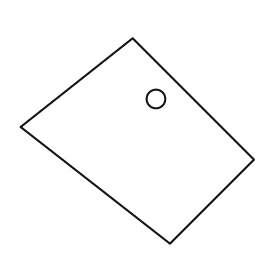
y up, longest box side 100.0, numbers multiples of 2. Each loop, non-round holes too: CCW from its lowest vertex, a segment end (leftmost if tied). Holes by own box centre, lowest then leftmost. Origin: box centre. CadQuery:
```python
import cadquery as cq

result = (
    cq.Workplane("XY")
    .moveTo(14.0, -44.0)
    .lineTo(50.0, -8.0)
    .lineTo(-2.0, 44.0)
    .lineTo(-50.0, 6.0)
    .close()
    .moveTo(8.0, 18.0)
    .circle(4.0)
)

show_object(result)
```